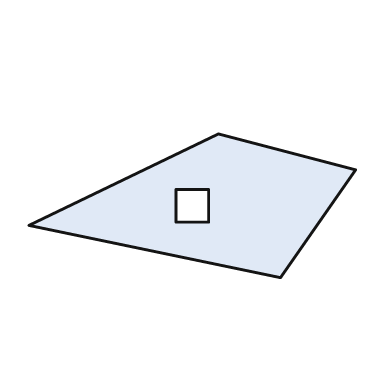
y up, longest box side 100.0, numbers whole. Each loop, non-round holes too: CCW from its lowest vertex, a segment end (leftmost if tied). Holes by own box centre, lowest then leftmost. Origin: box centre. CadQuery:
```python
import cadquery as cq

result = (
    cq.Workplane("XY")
    .moveTo(27.0, -22.0)
    .lineTo(50.0, 11.0)
    .lineTo(8.0, 22.0)
    .lineTo(-50.0, -6.0)
    .close()
    .moveTo(-5.0, -5.0)
    .lineTo(5.0, -5.0)
    .lineTo(5.0, 5.0)
    .lineTo(-5.0, 5.0)
    .close()
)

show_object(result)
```